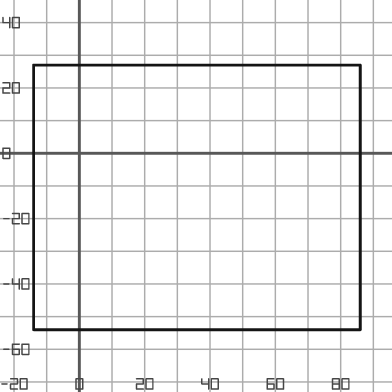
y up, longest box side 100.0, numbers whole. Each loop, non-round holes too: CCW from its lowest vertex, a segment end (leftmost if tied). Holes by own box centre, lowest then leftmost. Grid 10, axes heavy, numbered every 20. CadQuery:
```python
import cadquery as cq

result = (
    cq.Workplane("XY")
    .moveTo(-14.0, -54.0)
    .lineTo(86.0, -54.0)
    .lineTo(86.0, 27.0)
    .lineTo(-14.0, 27.0)
    .close()
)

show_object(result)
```